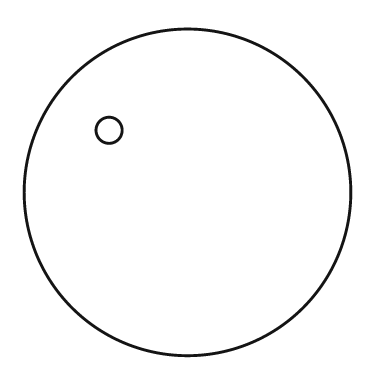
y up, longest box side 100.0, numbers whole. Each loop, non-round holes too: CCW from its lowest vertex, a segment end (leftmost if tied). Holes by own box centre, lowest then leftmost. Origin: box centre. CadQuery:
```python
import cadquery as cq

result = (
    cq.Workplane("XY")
    .moveTo(0.0, 0.0)
    .circle(50.0)
    .moveTo(-24.0, 19.0)
    .circle(4.0)
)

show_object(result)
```